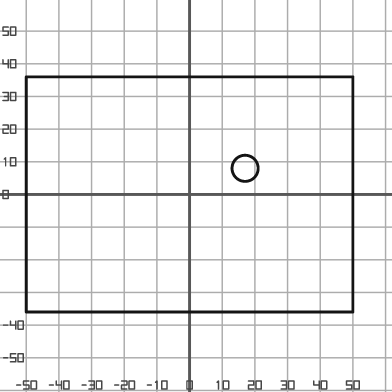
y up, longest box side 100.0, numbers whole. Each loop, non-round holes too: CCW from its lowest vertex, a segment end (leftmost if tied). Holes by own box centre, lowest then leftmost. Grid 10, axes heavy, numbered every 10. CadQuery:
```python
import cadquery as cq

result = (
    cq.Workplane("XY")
    .moveTo(-50.0, -36.0)
    .lineTo(50.0, -36.0)
    .lineTo(50.0, 36.0)
    .lineTo(-50.0, 36.0)
    .close()
    .moveTo(17.0, 8.0)
    .circle(4.0)
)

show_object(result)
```